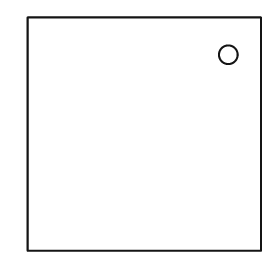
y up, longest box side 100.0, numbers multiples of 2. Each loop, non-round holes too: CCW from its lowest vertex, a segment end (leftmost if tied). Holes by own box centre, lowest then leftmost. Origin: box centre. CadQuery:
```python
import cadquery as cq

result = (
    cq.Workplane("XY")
    .moveTo(-50.0, -50.0)
    .lineTo(50.0, -50.0)
    .lineTo(50.0, 50.0)
    .lineTo(-50.0, 50.0)
    .close()
    .moveTo(36.0, 34.0)
    .circle(4.0)
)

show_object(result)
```